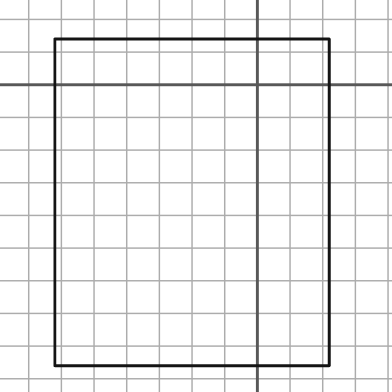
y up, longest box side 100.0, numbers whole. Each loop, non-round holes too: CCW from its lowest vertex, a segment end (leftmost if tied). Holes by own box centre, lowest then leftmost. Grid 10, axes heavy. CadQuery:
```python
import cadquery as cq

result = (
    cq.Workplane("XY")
    .moveTo(-62.0, -86.0)
    .lineTo(22.0, -86.0)
    .lineTo(22.0, 14.0)
    .lineTo(-62.0, 14.0)
    .close()
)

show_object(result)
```